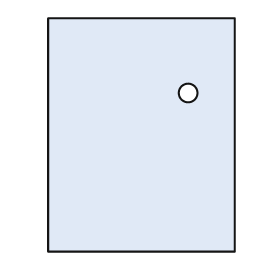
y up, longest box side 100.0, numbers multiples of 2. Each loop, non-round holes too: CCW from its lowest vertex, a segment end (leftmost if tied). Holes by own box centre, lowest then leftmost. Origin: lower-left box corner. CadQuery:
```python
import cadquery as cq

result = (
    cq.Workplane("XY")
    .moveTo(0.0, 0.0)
    .lineTo(80.0, 0.0)
    .lineTo(80.0, 100.0)
    .lineTo(0.0, 100.0)
    .close()
    .moveTo(60.0, 68.0)
    .circle(4.0)
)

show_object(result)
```